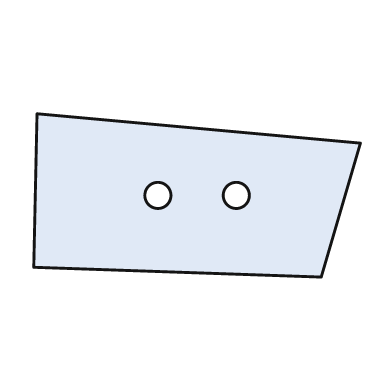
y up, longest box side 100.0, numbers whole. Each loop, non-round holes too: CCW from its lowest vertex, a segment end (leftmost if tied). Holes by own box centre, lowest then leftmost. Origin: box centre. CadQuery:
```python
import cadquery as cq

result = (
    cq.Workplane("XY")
    .moveTo(38.0, -25.0)
    .lineTo(50.0, 16.0)
    .lineTo(-49.0, 25.0)
    .lineTo(-50.0, -22.0)
    .close()
    .moveTo(-12.0, 0.0)
    .circle(4.0)
    .moveTo(12.0, 0.0)
    .circle(4.0)
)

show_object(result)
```